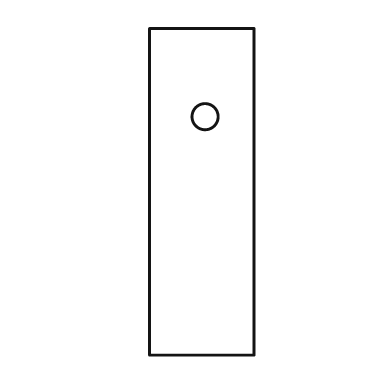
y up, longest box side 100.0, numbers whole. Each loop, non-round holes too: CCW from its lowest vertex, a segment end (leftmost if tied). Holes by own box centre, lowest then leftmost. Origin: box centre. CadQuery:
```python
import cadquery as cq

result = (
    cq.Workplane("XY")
    .moveTo(-16.0, -50.0)
    .lineTo(16.0, -50.0)
    .lineTo(16.0, 50.0)
    .lineTo(-16.0, 50.0)
    .close()
    .moveTo(1.0, 23.0)
    .circle(4.0)
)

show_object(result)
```